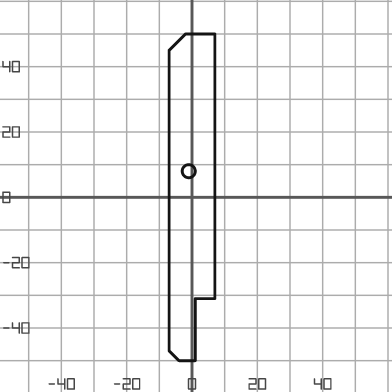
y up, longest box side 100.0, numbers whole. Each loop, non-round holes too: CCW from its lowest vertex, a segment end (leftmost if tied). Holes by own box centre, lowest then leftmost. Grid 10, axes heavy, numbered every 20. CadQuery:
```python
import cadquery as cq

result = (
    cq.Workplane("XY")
    .moveTo(-4.0, -50.0)
    .lineTo(1.0, -50.0)
    .lineTo(1.0, -31.0)
    .lineTo(7.0, -31.0)
    .lineTo(7.0, 50.0)
    .lineTo(-2.0, 50.0)
    .lineTo(-7.0, 45.0)
    .lineTo(-7.0, -47.0)
    .close()
    .moveTo(-1.0, 8.0)
    .circle(2.0)
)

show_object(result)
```